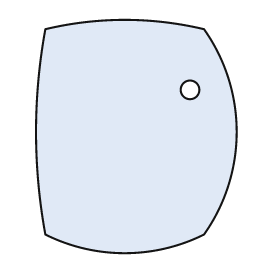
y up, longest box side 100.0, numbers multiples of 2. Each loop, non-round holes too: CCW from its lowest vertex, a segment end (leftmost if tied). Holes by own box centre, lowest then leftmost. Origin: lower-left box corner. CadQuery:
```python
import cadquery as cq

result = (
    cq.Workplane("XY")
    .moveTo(4.0, 8.0)
    .threePointArc((38.0, 0.0), (72.0, 8.0))
    .threePointArc((86.0, 52.0), (72.0, 96.0))
    .threePointArc((38.0, 100.0), (4.0, 96.0))
    .threePointArc((0.0, 52.0), (4.0, 8.0))
    .close()
    .moveTo(66.0, 70.0)
    .circle(4.0)
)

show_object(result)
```